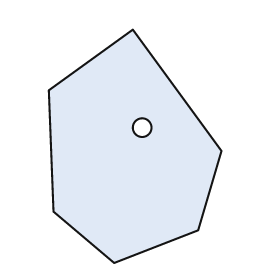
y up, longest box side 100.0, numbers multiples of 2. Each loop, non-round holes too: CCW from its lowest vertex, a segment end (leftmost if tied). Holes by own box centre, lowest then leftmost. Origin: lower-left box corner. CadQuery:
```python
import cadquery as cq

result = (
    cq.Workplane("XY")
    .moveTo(28.0, 0.0)
    .lineTo(64.0, 14.0)
    .lineTo(74.0, 48.0)
    .lineTo(36.0, 100.0)
    .lineTo(0.0, 74.0)
    .lineTo(2.0, 22.0)
    .close()
    .moveTo(40.0, 58.0)
    .circle(4.0)
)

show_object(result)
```